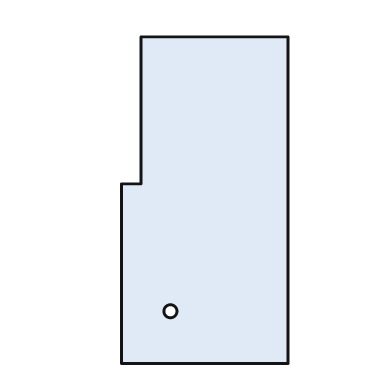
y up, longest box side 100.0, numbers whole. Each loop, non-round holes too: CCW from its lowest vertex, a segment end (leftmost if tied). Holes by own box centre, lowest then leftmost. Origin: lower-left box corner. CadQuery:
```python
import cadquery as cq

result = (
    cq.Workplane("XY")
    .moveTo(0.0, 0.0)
    .lineTo(51.0, 0.0)
    .lineTo(51.0, 100.0)
    .lineTo(6.0, 100.0)
    .lineTo(6.0, 55.0)
    .lineTo(0.0, 55.0)
    .close()
    .moveTo(15.0, 16.0)
    .circle(2.0)
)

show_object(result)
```